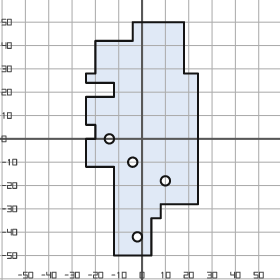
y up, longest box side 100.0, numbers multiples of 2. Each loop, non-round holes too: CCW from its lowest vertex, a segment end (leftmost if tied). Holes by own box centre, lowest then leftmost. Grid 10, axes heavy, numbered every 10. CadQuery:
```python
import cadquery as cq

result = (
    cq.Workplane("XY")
    .moveTo(-12.0, -50.0)
    .lineTo(4.0, -50.0)
    .lineTo(4.0, -34.0)
    .lineTo(8.0, -34.0)
    .lineTo(8.0, -28.0)
    .lineTo(24.0, -28.0)
    .lineTo(24.0, 28.0)
    .lineTo(18.0, 28.0)
    .lineTo(18.0, 50.0)
    .lineTo(-4.0, 50.0)
    .lineTo(-4.0, 42.0)
    .lineTo(-20.0, 42.0)
    .lineTo(-20.0, 28.0)
    .lineTo(-24.0, 28.0)
    .lineTo(-24.0, 24.0)
    .lineTo(-12.0, 24.0)
    .lineTo(-12.0, 18.0)
    .lineTo(-24.0, 18.0)
    .lineTo(-24.0, 6.0)
    .lineTo(-20.0, 6.0)
    .lineTo(-20.0, 0.0)
    .lineTo(-24.0, 0.0)
    .lineTo(-24.0, -12.0)
    .lineTo(-12.0, -12.0)
    .close()
    .moveTo(-2.0, -42.0)
    .circle(2.0)
    .moveTo(10.0, -18.0)
    .circle(2.0)
    .moveTo(-4.0, -10.0)
    .circle(2.0)
    .moveTo(-14.0, 0.0)
    .circle(2.0)
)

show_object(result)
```